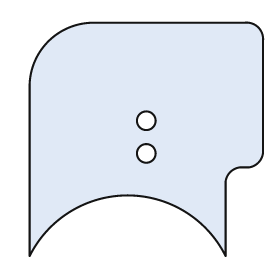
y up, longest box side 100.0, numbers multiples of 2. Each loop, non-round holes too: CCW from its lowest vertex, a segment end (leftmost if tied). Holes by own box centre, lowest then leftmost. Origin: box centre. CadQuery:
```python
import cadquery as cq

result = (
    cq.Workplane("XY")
    .moveTo(-50.0, -50.0)
    .threePointArc((-8.0, -24.0), (34.0, -50.0))
    .lineTo(34.0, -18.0)
    .threePointArc((36.0, -14.0), (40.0, -12.0))
    .lineTo(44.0, -12.0)
    .threePointArc((48.0, -10.0), (50.0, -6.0))
    .lineTo(50.0, 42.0)
    .threePointArc((48.0, 48.0), (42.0, 50.0))
    .lineTo(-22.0, 50.0)
    .threePointArc((-42.0, 42.0), (-50.0, 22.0))
    .close()
    .moveTo(0.0, -6.0)
    .circle(4.0)
    .moveTo(0.0, 8.0)
    .circle(4.0)
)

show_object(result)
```